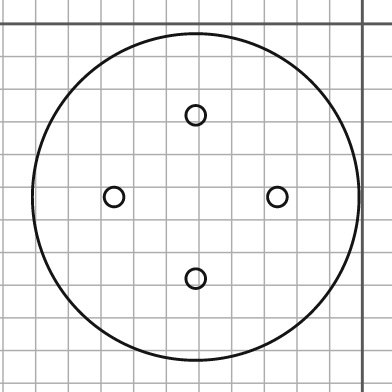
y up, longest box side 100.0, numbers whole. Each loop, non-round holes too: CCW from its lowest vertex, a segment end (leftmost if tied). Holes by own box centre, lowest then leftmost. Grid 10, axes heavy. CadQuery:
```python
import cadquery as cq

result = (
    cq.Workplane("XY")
    .moveTo(-51.0, -53.0)
    .circle(50.0)
    .moveTo(-51.0, -78.0)
    .circle(3.0)
    .moveTo(-76.0, -53.0)
    .circle(3.0)
    .moveTo(-26.0, -53.0)
    .circle(3.0)
    .moveTo(-51.0, -28.0)
    .circle(3.0)
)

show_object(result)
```